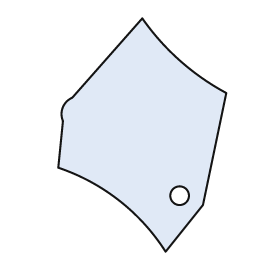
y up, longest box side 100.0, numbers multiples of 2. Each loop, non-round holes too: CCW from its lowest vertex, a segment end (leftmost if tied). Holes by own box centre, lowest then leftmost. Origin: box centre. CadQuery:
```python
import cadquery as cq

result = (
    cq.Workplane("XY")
    .moveTo(10.0, -50.0)
    .lineTo(26.0, -30.0)
    .lineTo(36.0, 18.0)
    .threePointArc((16.0, 32.0), (0.0, 50.0))
    .lineTo(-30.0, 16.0)
    .threePointArc((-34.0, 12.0), (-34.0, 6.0))
    .lineTo(-36.0, -14.0)
    .threePointArc((-10.0, -28.0), (10.0, -50.0))
    .close()
    .moveTo(16.0, -26.0)
    .circle(4.0)
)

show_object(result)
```